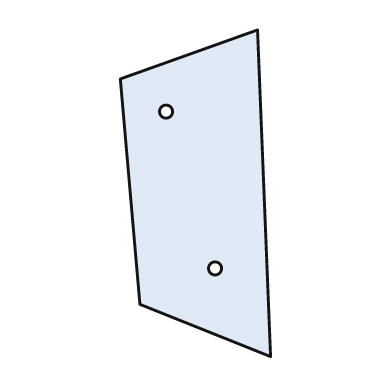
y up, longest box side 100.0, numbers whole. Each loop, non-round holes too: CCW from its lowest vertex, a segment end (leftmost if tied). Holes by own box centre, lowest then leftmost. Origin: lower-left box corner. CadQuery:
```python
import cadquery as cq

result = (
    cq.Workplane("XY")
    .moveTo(46.0, 0.0)
    .lineTo(42.0, 100.0)
    .lineTo(0.0, 85.0)
    .lineTo(6.0, 16.0)
    .close()
    .moveTo(29.0, 27.0)
    .circle(2.0)
    .moveTo(14.0, 75.0)
    .circle(2.0)
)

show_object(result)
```